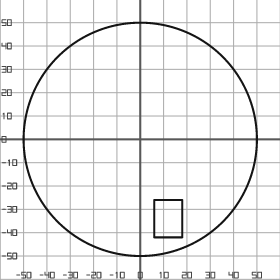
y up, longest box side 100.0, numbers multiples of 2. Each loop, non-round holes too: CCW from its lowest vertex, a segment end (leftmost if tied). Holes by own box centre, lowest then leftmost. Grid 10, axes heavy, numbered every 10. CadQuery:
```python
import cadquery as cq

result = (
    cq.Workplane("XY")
    .moveTo(0.0, 0.0)
    .circle(50.0)
    .moveTo(6.0, -42.0)
    .lineTo(18.0, -42.0)
    .lineTo(18.0, -26.0)
    .lineTo(6.0, -26.0)
    .close()
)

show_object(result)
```